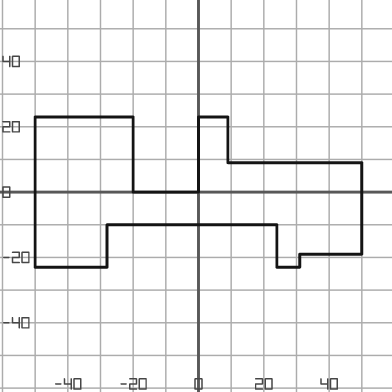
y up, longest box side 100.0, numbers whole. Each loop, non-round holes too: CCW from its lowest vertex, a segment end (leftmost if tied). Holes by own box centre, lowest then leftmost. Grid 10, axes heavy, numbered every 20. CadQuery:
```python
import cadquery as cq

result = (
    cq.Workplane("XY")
    .moveTo(-50.0, -23.0)
    .lineTo(-28.0, -23.0)
    .lineTo(-28.0, -10.0)
    .lineTo(24.0, -10.0)
    .lineTo(24.0, -23.0)
    .lineTo(31.0, -23.0)
    .lineTo(31.0, -19.0)
    .lineTo(50.0, -19.0)
    .lineTo(50.0, 9.0)
    .lineTo(9.0, 9.0)
    .lineTo(9.0, 23.0)
    .lineTo(0.0, 23.0)
    .lineTo(0.0, 0.0)
    .lineTo(-20.0, 0.0)
    .lineTo(-20.0, 23.0)
    .lineTo(-50.0, 23.0)
    .close()
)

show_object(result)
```